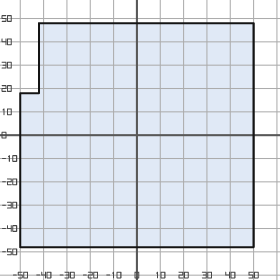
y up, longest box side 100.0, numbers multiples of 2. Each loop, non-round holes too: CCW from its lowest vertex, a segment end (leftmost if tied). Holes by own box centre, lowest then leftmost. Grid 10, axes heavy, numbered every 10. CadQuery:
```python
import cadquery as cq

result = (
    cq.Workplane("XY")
    .moveTo(-50.0, -48.0)
    .lineTo(50.0, -48.0)
    .lineTo(50.0, 48.0)
    .lineTo(-42.0, 48.0)
    .lineTo(-42.0, 18.0)
    .lineTo(-50.0, 18.0)
    .close()
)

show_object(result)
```